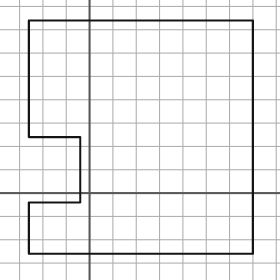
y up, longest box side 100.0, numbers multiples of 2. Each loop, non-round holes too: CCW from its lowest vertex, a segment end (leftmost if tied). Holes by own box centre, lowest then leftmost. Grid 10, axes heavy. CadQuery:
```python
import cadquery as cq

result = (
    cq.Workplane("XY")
    .moveTo(-26.0, -26.0)
    .lineTo(70.0, -26.0)
    .lineTo(70.0, 74.0)
    .lineTo(-26.0, 74.0)
    .lineTo(-26.0, 24.0)
    .lineTo(-4.0, 24.0)
    .lineTo(-4.0, -4.0)
    .lineTo(-26.0, -4.0)
    .close()
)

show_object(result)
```